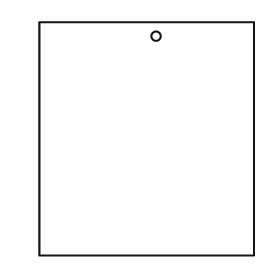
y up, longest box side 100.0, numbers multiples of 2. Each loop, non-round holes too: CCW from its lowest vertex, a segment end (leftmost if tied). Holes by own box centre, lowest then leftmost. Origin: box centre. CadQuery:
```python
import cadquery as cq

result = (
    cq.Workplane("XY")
    .moveTo(-46.0, -50.0)
    .lineTo(46.0, -50.0)
    .lineTo(46.0, 50.0)
    .lineTo(-46.0, 50.0)
    .close()
    .moveTo(4.0, 44.0)
    .circle(2.0)
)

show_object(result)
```